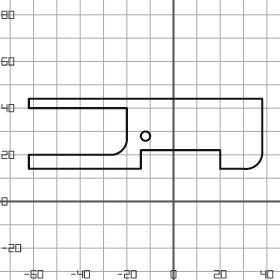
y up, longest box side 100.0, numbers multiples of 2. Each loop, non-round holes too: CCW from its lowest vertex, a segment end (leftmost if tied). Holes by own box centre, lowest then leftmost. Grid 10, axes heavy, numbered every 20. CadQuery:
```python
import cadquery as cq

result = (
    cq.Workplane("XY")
    .moveTo(-62.0, 14.0)
    .lineTo(-14.0, 14.0)
    .lineTo(-14.0, 22.0)
    .lineTo(20.0, 22.0)
    .lineTo(20.0, 14.0)
    .lineTo(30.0, 14.0)
    .threePointArc((36.0, 16.0), (38.0, 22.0))
    .lineTo(38.0, 44.0)
    .lineTo(-62.0, 44.0)
    .lineTo(-62.0, 40.0)
    .lineTo(-20.0, 40.0)
    .lineTo(-20.0, 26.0)
    .threePointArc((-22.0, 22.0), (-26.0, 20.0))
    .lineTo(-62.0, 20.0)
    .close()
    .moveTo(-12.0, 28.0)
    .circle(2.0)
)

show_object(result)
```